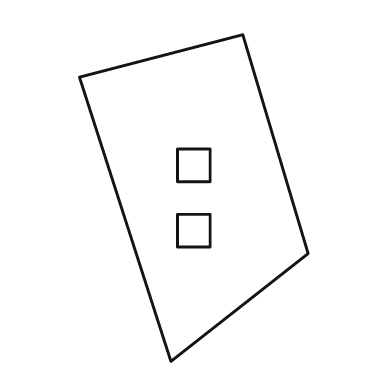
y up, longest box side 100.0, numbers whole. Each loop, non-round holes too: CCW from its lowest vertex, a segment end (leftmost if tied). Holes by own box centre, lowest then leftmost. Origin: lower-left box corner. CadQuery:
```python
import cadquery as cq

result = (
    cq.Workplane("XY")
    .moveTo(28.0, 0.0)
    .lineTo(70.0, 33.0)
    .lineTo(50.0, 100.0)
    .lineTo(0.0, 87.0)
    .close()
    .moveTo(30.0, 35.0)
    .lineTo(40.0, 35.0)
    .lineTo(40.0, 45.0)
    .lineTo(30.0, 45.0)
    .close()
    .moveTo(30.0, 55.0)
    .lineTo(40.0, 55.0)
    .lineTo(40.0, 65.0)
    .lineTo(30.0, 65.0)
    .close()
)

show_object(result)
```